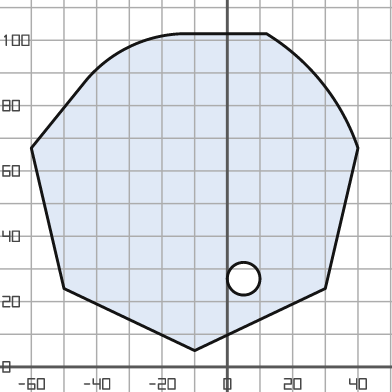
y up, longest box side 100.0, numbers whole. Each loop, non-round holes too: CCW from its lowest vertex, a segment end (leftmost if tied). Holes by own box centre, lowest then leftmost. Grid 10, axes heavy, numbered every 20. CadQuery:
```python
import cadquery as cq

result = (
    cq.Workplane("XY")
    .moveTo(-10.0, 5.0)
    .lineTo(30.0, 24.0)
    .lineTo(40.0, 67.0)
    .threePointArc((29.0, 87.0), (12.0, 102.0))
    .lineTo(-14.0, 102.0)
    .threePointArc((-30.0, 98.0), (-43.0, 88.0))
    .lineTo(-60.0, 67.0)
    .lineTo(-50.0, 24.0)
    .close()
    .moveTo(5.0, 27.0)
    .circle(5.0)
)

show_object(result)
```